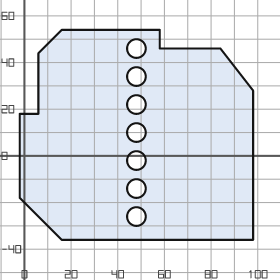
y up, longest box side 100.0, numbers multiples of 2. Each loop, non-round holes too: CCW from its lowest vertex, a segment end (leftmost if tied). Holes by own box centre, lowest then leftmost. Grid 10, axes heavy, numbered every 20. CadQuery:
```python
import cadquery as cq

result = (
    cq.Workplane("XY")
    .moveTo(16.0, -36.0)
    .lineTo(98.0, -36.0)
    .lineTo(98.0, 28.0)
    .lineTo(84.0, 46.0)
    .lineTo(58.0, 46.0)
    .lineTo(58.0, 54.0)
    .lineTo(16.0, 54.0)
    .lineTo(6.0, 44.0)
    .lineTo(6.0, 18.0)
    .lineTo(-2.0, 18.0)
    .lineTo(-2.0, -18.0)
    .close()
    .moveTo(48.0, -26.0)
    .circle(4.0)
    .moveTo(48.0, -14.0)
    .circle(4.0)
    .moveTo(48.0, -2.0)
    .circle(4.0)
    .moveTo(48.0, 10.0)
    .circle(4.0)
    .moveTo(48.0, 22.0)
    .circle(4.0)
    .moveTo(48.0, 34.0)
    .circle(4.0)
    .moveTo(48.0, 46.0)
    .circle(4.0)
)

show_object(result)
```